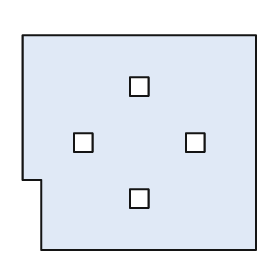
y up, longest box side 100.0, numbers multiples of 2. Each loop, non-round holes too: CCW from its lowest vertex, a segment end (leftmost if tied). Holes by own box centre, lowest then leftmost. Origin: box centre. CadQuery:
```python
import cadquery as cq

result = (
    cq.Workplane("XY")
    .moveTo(-42.0, -46.0)
    .lineTo(50.0, -46.0)
    .lineTo(50.0, 46.0)
    .lineTo(-50.0, 46.0)
    .lineTo(-50.0, -16.0)
    .lineTo(-42.0, -16.0)
    .close()
    .moveTo(-4.0, -28.0)
    .lineTo(4.0, -28.0)
    .lineTo(4.0, -20.0)
    .lineTo(-4.0, -20.0)
    .close()
    .moveTo(-28.0, -4.0)
    .lineTo(-20.0, -4.0)
    .lineTo(-20.0, 4.0)
    .lineTo(-28.0, 4.0)
    .close()
    .moveTo(20.0, -4.0)
    .lineTo(28.0, -4.0)
    .lineTo(28.0, 4.0)
    .lineTo(20.0, 4.0)
    .close()
    .moveTo(-4.0, 20.0)
    .lineTo(4.0, 20.0)
    .lineTo(4.0, 28.0)
    .lineTo(-4.0, 28.0)
    .close()
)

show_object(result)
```